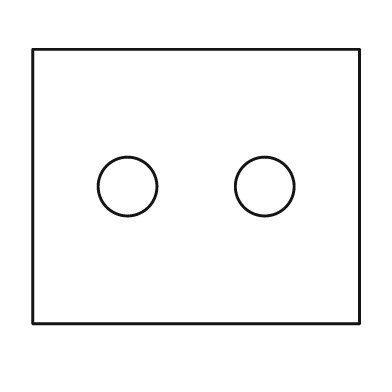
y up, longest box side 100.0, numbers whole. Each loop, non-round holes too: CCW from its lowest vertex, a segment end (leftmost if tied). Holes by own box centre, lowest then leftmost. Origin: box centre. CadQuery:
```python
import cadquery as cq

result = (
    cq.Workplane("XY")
    .moveTo(-50.0, -42.0)
    .lineTo(50.0, -42.0)
    .lineTo(50.0, 42.0)
    .lineTo(-50.0, 42.0)
    .close()
    .moveTo(-21.0, 0.0)
    .circle(9.0)
    .moveTo(21.0, 0.0)
    .circle(9.0)
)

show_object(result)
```